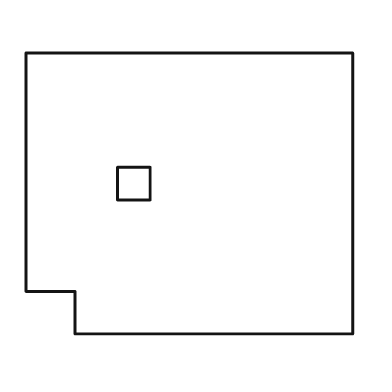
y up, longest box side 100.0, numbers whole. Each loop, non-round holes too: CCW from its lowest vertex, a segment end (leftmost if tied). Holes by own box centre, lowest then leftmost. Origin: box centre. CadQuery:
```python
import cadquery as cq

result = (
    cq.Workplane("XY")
    .moveTo(-35.0, -43.0)
    .lineTo(50.0, -43.0)
    .lineTo(50.0, 43.0)
    .lineTo(-50.0, 43.0)
    .lineTo(-50.0, -30.0)
    .lineTo(-35.0, -30.0)
    .close()
    .moveTo(-22.0, -2.0)
    .lineTo(-12.0, -2.0)
    .lineTo(-12.0, 8.0)
    .lineTo(-22.0, 8.0)
    .close()
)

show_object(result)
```